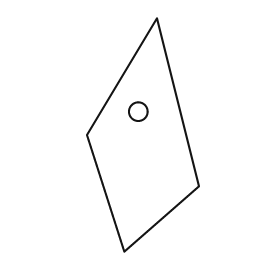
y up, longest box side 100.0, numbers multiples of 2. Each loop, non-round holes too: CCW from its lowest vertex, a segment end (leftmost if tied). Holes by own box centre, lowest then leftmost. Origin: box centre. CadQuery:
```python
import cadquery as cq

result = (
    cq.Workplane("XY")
    .moveTo(-8.0, -50.0)
    .lineTo(24.0, -22.0)
    .lineTo(6.0, 50.0)
    .lineTo(-24.0, 0.0)
    .close()
    .moveTo(-2.0, 10.0)
    .circle(4.0)
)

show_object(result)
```